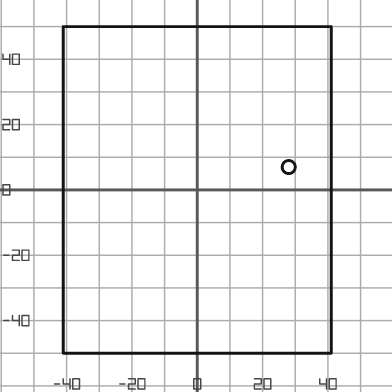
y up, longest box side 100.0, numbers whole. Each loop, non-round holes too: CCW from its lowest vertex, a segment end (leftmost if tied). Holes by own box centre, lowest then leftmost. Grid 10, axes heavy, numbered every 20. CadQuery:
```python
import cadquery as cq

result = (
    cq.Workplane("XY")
    .moveTo(-41.0, -50.0)
    .lineTo(41.0, -50.0)
    .lineTo(41.0, 50.0)
    .lineTo(-41.0, 50.0)
    .close()
    .moveTo(28.0, 7.0)
    .circle(2.0)
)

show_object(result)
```